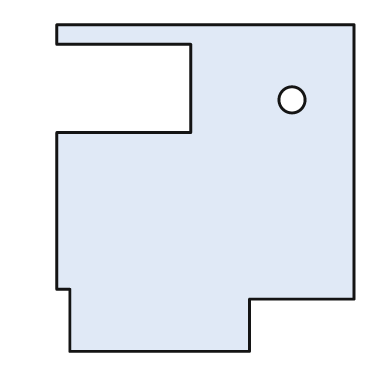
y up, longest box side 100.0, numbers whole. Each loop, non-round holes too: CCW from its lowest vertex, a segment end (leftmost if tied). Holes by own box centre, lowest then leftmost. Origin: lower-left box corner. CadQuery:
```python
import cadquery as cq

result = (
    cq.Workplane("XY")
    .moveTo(4.0, 0.0)
    .lineTo(59.0, 0.0)
    .lineTo(59.0, 16.0)
    .lineTo(91.0, 16.0)
    .lineTo(91.0, 100.0)
    .lineTo(0.0, 100.0)
    .lineTo(0.0, 94.0)
    .lineTo(41.0, 94.0)
    .lineTo(41.0, 67.0)
    .lineTo(0.0, 67.0)
    .lineTo(0.0, 19.0)
    .lineTo(4.0, 19.0)
    .close()
    .moveTo(72.0, 77.0)
    .circle(4.0)
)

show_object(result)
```